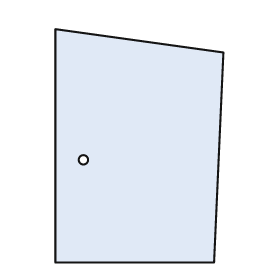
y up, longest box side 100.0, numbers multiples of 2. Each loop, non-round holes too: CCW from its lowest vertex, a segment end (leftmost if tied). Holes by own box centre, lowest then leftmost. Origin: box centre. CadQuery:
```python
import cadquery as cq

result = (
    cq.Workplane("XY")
    .moveTo(-36.0, -50.0)
    .lineTo(32.0, -50.0)
    .lineTo(36.0, 40.0)
    .lineTo(-36.0, 50.0)
    .close()
    .moveTo(-24.0, -6.0)
    .circle(2.0)
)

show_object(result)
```